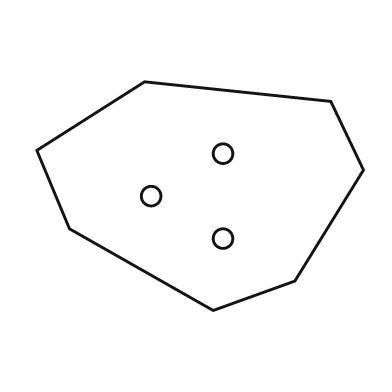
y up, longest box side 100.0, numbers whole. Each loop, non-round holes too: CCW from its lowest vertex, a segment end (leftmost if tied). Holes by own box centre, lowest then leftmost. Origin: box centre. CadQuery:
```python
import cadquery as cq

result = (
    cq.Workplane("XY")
    .moveTo(4.0, -35.0)
    .lineTo(29.0, -26.0)
    .lineTo(50.0, 8.0)
    .lineTo(40.0, 29.0)
    .lineTo(-17.0, 35.0)
    .lineTo(-50.0, 14.0)
    .lineTo(-40.0, -10.0)
    .close()
    .moveTo(7.0, -13.0)
    .circle(3.0)
    .moveTo(-15.0, 0.0)
    .circle(3.0)
    .moveTo(7.0, 13.0)
    .circle(3.0)
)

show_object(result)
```